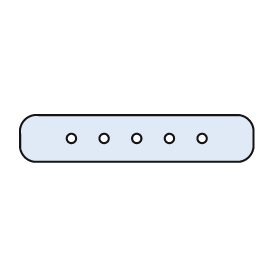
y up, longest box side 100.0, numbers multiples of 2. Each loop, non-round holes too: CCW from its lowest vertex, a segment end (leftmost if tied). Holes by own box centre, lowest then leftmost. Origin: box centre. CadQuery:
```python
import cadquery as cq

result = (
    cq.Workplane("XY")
    .moveTo(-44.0, -10.0)
    .lineTo(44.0, -10.0)
    .threePointArc((48.0, -8.0), (50.0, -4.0))
    .lineTo(50.0, 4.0)
    .threePointArc((48.0, 8.0), (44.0, 10.0))
    .lineTo(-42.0, 10.0)
    .threePointArc((-48.0, 8.0), (-50.0, 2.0))
    .lineTo(-50.0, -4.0)
    .threePointArc((-48.0, -8.0), (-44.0, -10.0))
    .close()
    .moveTo(-28.0, 0.0)
    .circle(2.0)
    .moveTo(-14.0, 0.0)
    .circle(2.0)
    .moveTo(0.0, 0.0)
    .circle(2.0)
    .moveTo(14.0, 0.0)
    .circle(2.0)
    .moveTo(28.0, 0.0)
    .circle(2.0)
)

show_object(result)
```